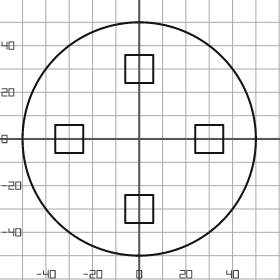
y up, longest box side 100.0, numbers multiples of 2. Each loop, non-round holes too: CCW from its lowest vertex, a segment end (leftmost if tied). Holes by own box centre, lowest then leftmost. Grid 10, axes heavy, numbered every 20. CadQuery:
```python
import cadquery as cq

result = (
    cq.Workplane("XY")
    .moveTo(0.0, 0.0)
    .circle(50.0)
    .moveTo(-6.0, -36.0)
    .lineTo(6.0, -36.0)
    .lineTo(6.0, -24.0)
    .lineTo(-6.0, -24.0)
    .close()
    .moveTo(-36.0, -6.0)
    .lineTo(-24.0, -6.0)
    .lineTo(-24.0, 6.0)
    .lineTo(-36.0, 6.0)
    .close()
    .moveTo(24.0, -6.0)
    .lineTo(36.0, -6.0)
    .lineTo(36.0, 6.0)
    .lineTo(24.0, 6.0)
    .close()
    .moveTo(-6.0, 24.0)
    .lineTo(6.0, 24.0)
    .lineTo(6.0, 36.0)
    .lineTo(-6.0, 36.0)
    .close()
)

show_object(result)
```